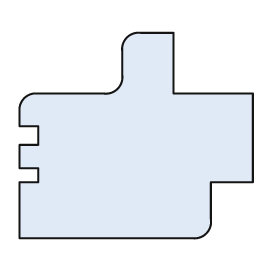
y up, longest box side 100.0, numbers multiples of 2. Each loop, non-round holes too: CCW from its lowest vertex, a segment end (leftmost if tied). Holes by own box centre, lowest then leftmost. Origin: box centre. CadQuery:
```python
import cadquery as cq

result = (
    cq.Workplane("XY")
    .moveTo(-50.0, -44.0)
    .lineTo(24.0, -44.0)
    .threePointArc((30.0, -42.0), (32.0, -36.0))
    .lineTo(32.0, -20.0)
    .lineTo(50.0, -20.0)
    .lineTo(50.0, 18.0)
    .lineTo(16.0, 18.0)
    .lineTo(16.0, 44.0)
    .lineTo(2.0, 44.0)
    .threePointArc((-4.0, 42.0), (-6.0, 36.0))
    .lineTo(-6.0, 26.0)
    .threePointArc((-8.0, 20.0), (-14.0, 18.0))
    .lineTo(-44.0, 18.0)
    .threePointArc((-48.0, 16.0), (-50.0, 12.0))
    .lineTo(-50.0, 4.0)
    .lineTo(-42.0, 4.0)
    .lineTo(-42.0, -4.0)
    .lineTo(-50.0, -4.0)
    .lineTo(-50.0, -14.0)
    .lineTo(-42.0, -14.0)
    .lineTo(-42.0, -20.0)
    .lineTo(-50.0, -20.0)
    .close()
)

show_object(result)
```